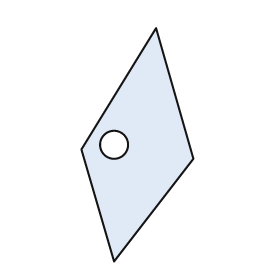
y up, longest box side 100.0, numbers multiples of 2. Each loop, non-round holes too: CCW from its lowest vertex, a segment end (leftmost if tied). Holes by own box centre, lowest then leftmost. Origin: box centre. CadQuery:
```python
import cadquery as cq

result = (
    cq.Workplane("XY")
    .moveTo(-10.0, -50.0)
    .lineTo(24.0, -6.0)
    .lineTo(8.0, 50.0)
    .lineTo(-24.0, -2.0)
    .close()
    .moveTo(-10.0, 0.0)
    .circle(6.0)
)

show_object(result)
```